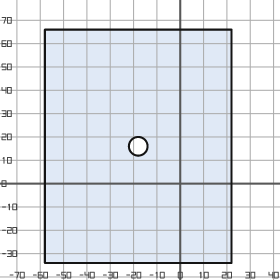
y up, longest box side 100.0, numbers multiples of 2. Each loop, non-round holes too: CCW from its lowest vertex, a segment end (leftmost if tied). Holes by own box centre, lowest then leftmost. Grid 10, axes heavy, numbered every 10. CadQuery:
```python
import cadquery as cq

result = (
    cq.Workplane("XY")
    .moveTo(-58.0, -34.0)
    .lineTo(22.0, -34.0)
    .lineTo(22.0, 66.0)
    .lineTo(-58.0, 66.0)
    .close()
    .moveTo(-18.0, 16.0)
    .circle(4.0)
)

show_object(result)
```